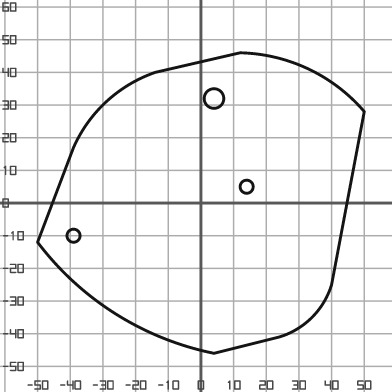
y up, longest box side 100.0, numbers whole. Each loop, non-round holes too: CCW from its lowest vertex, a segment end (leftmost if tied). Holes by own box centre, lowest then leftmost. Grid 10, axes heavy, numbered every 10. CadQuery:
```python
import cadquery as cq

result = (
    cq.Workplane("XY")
    .moveTo(4.0, -46.0)
    .lineTo(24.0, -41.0)
    .threePointArc((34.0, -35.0), (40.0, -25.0))
    .lineTo(50.0, 28.0)
    .threePointArc((33.0, 41.0), (12.0, 46.0))
    .lineTo(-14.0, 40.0)
    .threePointArc((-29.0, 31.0), (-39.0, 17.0))
    .lineTo(-50.0, -12.0)
    .threePointArc((-26.0, -34.0), (4.0, -46.0))
    .close()
    .moveTo(-39.0, -10.0)
    .circle(2.0)
    .moveTo(14.0, 5.0)
    .circle(2.0)
    .moveTo(4.0, 32.0)
    .circle(3.0)
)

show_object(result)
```